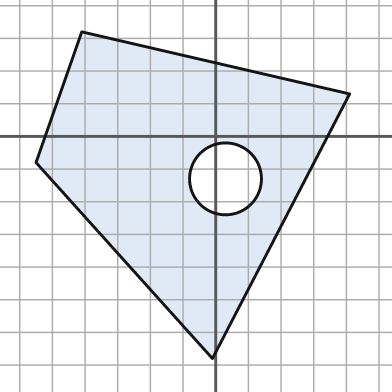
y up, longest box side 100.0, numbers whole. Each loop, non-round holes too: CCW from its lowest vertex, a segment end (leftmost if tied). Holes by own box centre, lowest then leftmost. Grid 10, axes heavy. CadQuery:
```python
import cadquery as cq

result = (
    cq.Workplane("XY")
    .moveTo(-1.0, -68.0)
    .lineTo(41.0, 13.0)
    .lineTo(-41.0, 32.0)
    .lineTo(-55.0, -8.0)
    .close()
    .moveTo(3.0, -13.0)
    .circle(11.0)
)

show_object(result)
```